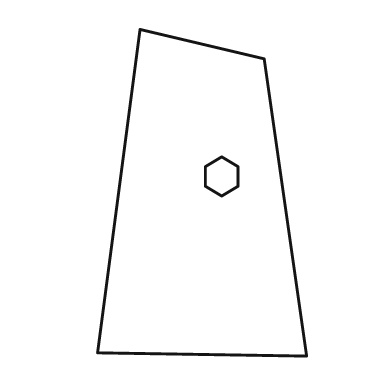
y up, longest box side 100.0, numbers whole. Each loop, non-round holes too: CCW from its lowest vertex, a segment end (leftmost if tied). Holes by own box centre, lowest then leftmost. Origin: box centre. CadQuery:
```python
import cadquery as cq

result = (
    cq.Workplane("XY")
    .moveTo(32.0, -50.0)
    .lineTo(19.0, 41.0)
    .lineTo(-19.0, 50.0)
    .lineTo(-32.0, -49.0)
    .close()
    .moveTo(6.0, -1.0)
    .lineTo(11.0, 2.0)
    .lineTo(11.0, 8.0)
    .lineTo(6.0, 11.0)
    .lineTo(1.0, 8.0)
    .lineTo(1.0, 2.0)
    .close()
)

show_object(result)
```